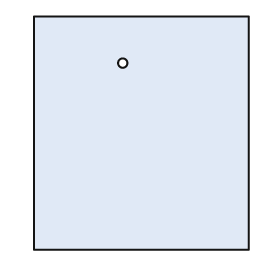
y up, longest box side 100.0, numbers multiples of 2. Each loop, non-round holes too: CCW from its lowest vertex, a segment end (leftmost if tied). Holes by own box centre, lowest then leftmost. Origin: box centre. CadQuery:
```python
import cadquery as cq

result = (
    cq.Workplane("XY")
    .moveTo(-46.0, -50.0)
    .lineTo(46.0, -50.0)
    .lineTo(46.0, 50.0)
    .lineTo(-46.0, 50.0)
    .close()
    .moveTo(-8.0, 30.0)
    .circle(2.0)
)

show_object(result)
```